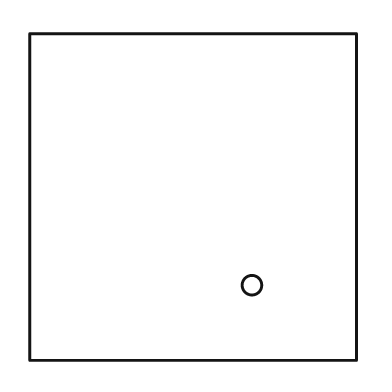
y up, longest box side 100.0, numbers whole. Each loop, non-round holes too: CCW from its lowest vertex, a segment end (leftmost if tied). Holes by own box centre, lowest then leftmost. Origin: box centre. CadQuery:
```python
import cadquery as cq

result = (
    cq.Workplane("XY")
    .moveTo(-50.0, -50.0)
    .lineTo(50.0, -50.0)
    .lineTo(50.0, 50.0)
    .lineTo(-50.0, 50.0)
    .close()
    .moveTo(18.0, -27.0)
    .circle(3.0)
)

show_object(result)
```